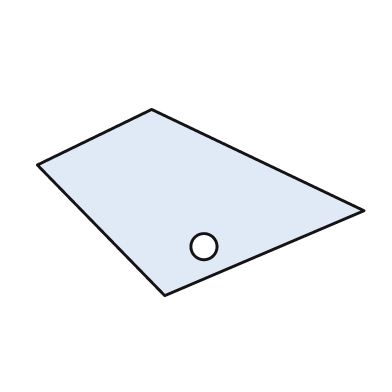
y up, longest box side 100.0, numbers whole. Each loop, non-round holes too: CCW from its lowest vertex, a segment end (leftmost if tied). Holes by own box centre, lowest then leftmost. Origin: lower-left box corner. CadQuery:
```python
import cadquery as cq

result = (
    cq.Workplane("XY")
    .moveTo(39.0, 0.0)
    .lineTo(100.0, 26.0)
    .lineTo(35.0, 57.0)
    .lineTo(0.0, 40.0)
    .close()
    .moveTo(51.0, 15.0)
    .circle(4.0)
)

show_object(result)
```